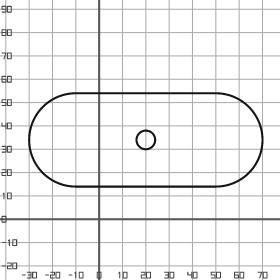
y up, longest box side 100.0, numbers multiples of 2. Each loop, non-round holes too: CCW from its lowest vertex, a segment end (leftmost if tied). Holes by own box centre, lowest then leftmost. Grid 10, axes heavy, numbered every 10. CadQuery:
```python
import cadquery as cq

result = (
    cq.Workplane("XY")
    .moveTo(-10.0, 14.0)
    .lineTo(50.0, 14.0)
    .threePointArc((70.0, 34.0), (50.0, 54.0))
    .lineTo(-10.0, 54.0)
    .threePointArc((-30.0, 34.0), (-10.0, 14.0))
    .close()
    .moveTo(20.0, 34.0)
    .circle(4.0)
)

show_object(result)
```